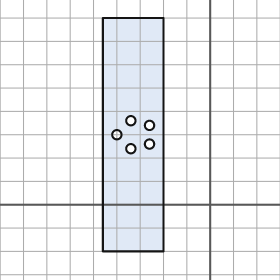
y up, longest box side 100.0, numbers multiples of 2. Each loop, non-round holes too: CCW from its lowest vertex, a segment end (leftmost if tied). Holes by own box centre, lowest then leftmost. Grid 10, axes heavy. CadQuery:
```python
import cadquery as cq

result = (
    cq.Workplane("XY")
    .moveTo(-46.0, -20.0)
    .lineTo(-20.0, -20.0)
    .lineTo(-20.0, 80.0)
    .lineTo(-46.0, 80.0)
    .close()
    .moveTo(-34.0, 24.0)
    .circle(2.0)
    .moveTo(-26.0, 26.0)
    .circle(2.0)
    .moveTo(-40.0, 30.0)
    .circle(2.0)
    .moveTo(-26.0, 34.0)
    .circle(2.0)
    .moveTo(-34.0, 36.0)
    .circle(2.0)
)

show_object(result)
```